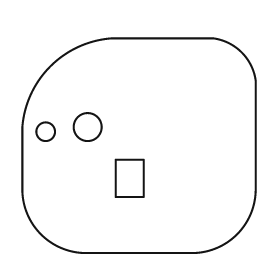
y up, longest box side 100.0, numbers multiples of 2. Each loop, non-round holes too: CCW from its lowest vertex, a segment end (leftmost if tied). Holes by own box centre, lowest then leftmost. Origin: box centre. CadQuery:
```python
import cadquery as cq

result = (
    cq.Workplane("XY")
    .moveTo(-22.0, -46.0)
    .lineTo(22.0, -46.0)
    .threePointArc((42.0, -38.0), (50.0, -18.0))
    .lineTo(50.0, 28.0)
    .threePointArc((44.0, 40.0), (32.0, 46.0))
    .lineTo(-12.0, 46.0)
    .threePointArc((-38.0, 34.0), (-50.0, 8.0))
    .lineTo(-50.0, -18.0)
    .threePointArc((-42.0, -38.0), (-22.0, -46.0))
    .close()
    .moveTo(-10.0, -22.0)
    .lineTo(2.0, -22.0)
    .lineTo(2.0, -6.0)
    .lineTo(-10.0, -6.0)
    .close()
    .moveTo(-40.0, 6.0)
    .circle(4.0)
    .moveTo(-22.0, 8.0)
    .circle(6.0)
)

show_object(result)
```